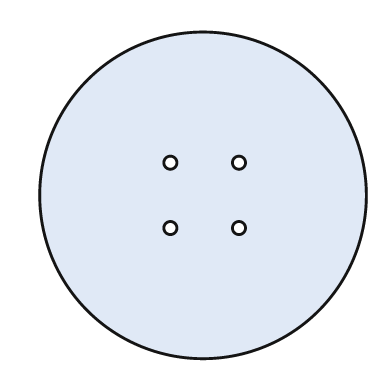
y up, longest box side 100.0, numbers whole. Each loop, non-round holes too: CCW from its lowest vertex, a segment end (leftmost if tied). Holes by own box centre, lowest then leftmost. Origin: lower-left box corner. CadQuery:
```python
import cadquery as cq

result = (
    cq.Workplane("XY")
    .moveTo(50.0, 50.0)
    .circle(50.0)
    .moveTo(40.0, 40.0)
    .circle(2.0)
    .moveTo(61.0, 40.0)
    .circle(2.0)
    .moveTo(40.0, 60.0)
    .circle(2.0)
    .moveTo(61.0, 60.0)
    .circle(2.0)
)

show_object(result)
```